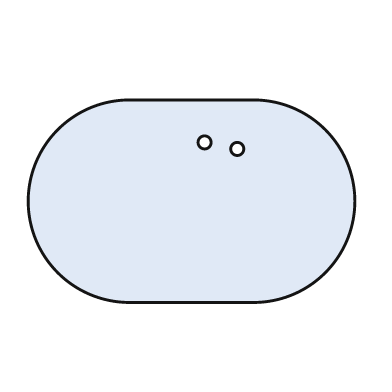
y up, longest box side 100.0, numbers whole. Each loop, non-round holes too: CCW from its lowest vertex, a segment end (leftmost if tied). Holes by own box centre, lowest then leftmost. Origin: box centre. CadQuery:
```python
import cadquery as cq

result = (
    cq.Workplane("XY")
    .moveTo(-19.0, -31.0)
    .lineTo(19.0, -31.0)
    .threePointArc((50.0, 0.0), (19.0, 31.0))
    .lineTo(-19.0, 31.0)
    .threePointArc((-50.0, 0.0), (-19.0, -31.0))
    .close()
    .moveTo(14.0, 16.0)
    .circle(2.0)
    .moveTo(4.0, 18.0)
    .circle(2.0)
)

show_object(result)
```